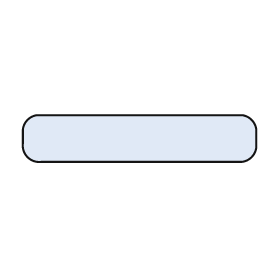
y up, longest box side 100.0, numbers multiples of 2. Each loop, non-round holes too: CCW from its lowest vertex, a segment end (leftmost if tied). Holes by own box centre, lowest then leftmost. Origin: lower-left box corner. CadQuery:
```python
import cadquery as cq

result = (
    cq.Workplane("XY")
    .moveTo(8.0, 0.0)
    .lineTo(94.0, 0.0)
    .threePointArc((98.0, 2.0), (100.0, 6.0))
    .lineTo(100.0, 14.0)
    .threePointArc((98.0, 18.0), (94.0, 20.0))
    .lineTo(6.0, 20.0)
    .threePointArc((2.0, 18.0), (0.0, 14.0))
    .lineTo(0.0, 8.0)
    .threePointArc((2.0, 2.0), (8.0, 0.0))
    .close()
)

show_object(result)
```